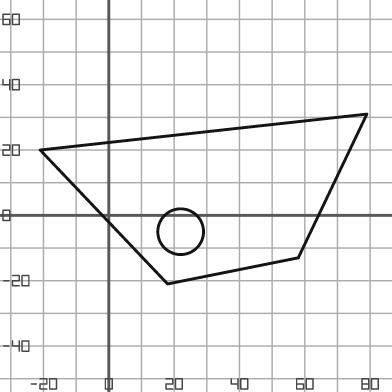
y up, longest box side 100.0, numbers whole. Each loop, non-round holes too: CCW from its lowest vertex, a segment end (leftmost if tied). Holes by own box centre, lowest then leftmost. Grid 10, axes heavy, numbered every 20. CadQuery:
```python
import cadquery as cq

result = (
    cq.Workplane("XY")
    .moveTo(18.0, -21.0)
    .lineTo(58.0, -13.0)
    .lineTo(79.0, 31.0)
    .lineTo(-21.0, 20.0)
    .close()
    .moveTo(22.0, -5.0)
    .circle(7.0)
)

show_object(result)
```